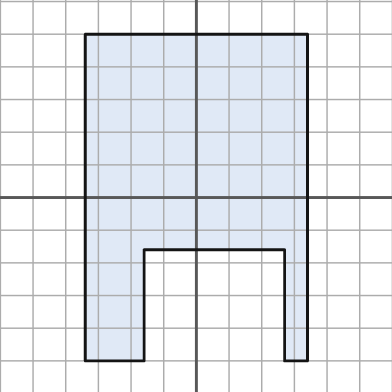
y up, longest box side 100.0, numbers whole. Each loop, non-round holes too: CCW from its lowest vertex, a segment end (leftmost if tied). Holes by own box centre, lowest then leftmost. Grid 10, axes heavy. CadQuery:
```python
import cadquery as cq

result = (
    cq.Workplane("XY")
    .moveTo(-34.0, -50.0)
    .lineTo(-16.0, -50.0)
    .lineTo(-16.0, -16.0)
    .lineTo(27.0, -16.0)
    .lineTo(27.0, -50.0)
    .lineTo(34.0, -50.0)
    .lineTo(34.0, 50.0)
    .lineTo(-34.0, 50.0)
    .close()
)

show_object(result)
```